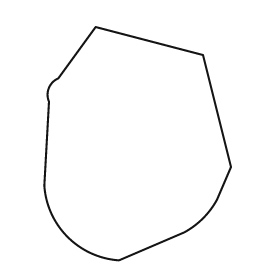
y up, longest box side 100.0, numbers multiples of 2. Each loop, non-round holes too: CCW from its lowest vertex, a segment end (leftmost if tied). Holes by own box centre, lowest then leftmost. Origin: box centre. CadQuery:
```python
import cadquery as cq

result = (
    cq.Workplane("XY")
    .moveTo(-8.0, -50.0)
    .lineTo(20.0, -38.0)
    .threePointArc((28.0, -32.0), (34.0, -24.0))
    .lineTo(40.0, -10.0)
    .lineTo(28.0, 38.0)
    .lineTo(-18.0, 50.0)
    .lineTo(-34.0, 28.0)
    .threePointArc((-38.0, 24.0), (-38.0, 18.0))
    .lineTo(-40.0, -18.0)
    .threePointArc((-30.0, -40.0), (-8.0, -50.0))
    .close()
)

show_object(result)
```